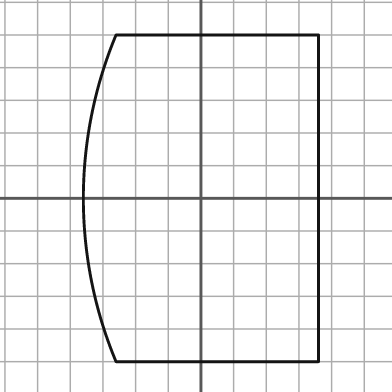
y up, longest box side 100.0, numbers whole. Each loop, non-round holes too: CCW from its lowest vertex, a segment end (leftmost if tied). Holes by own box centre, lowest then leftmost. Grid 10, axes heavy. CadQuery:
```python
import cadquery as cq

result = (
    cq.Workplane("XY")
    .moveTo(-26.0, -50.0)
    .lineTo(36.0, -50.0)
    .lineTo(36.0, 50.0)
    .lineTo(-26.0, 50.0)
    .threePointArc((-36.0, 0.0), (-26.0, -50.0))
    .close()
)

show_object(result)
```